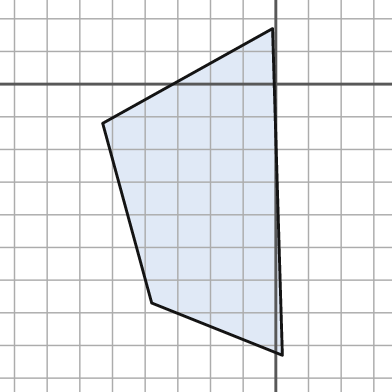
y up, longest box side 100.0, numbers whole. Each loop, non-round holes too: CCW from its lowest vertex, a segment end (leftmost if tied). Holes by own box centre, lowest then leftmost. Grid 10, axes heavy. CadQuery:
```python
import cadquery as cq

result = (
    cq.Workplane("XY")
    .moveTo(2.0, -83.0)
    .lineTo(-1.0, 17.0)
    .lineTo(-53.0, -12.0)
    .lineTo(-38.0, -67.0)
    .close()
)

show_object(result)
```